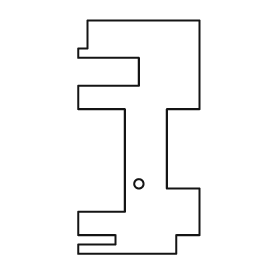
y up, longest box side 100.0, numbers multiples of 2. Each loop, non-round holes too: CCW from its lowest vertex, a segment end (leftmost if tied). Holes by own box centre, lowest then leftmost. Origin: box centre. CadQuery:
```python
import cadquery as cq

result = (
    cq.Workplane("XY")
    .moveTo(-26.0, -50.0)
    .lineTo(16.0, -50.0)
    .lineTo(16.0, -42.0)
    .lineTo(26.0, -42.0)
    .lineTo(26.0, -22.0)
    .lineTo(12.0, -22.0)
    .lineTo(12.0, 12.0)
    .lineTo(26.0, 12.0)
    .lineTo(26.0, 50.0)
    .lineTo(-22.0, 50.0)
    .lineTo(-22.0, 38.0)
    .lineTo(-26.0, 38.0)
    .lineTo(-26.0, 34.0)
    .lineTo(0.0, 34.0)
    .lineTo(0.0, 22.0)
    .lineTo(-26.0, 22.0)
    .lineTo(-26.0, 12.0)
    .lineTo(-6.0, 12.0)
    .lineTo(-6.0, -32.0)
    .lineTo(-26.0, -32.0)
    .lineTo(-26.0, -42.0)
    .lineTo(-10.0, -42.0)
    .lineTo(-10.0, -46.0)
    .lineTo(-26.0, -46.0)
    .close()
    .moveTo(0.0, -20.0)
    .circle(2.0)
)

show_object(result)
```